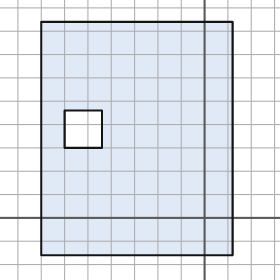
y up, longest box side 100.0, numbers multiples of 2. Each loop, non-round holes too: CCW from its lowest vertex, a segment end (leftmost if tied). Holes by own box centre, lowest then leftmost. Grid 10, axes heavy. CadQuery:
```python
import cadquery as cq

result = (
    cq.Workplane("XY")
    .moveTo(-70.0, -16.0)
    .lineTo(12.0, -16.0)
    .lineTo(12.0, 84.0)
    .lineTo(-70.0, 84.0)
    .close()
    .moveTo(-60.0, 30.0)
    .lineTo(-44.0, 30.0)
    .lineTo(-44.0, 46.0)
    .lineTo(-60.0, 46.0)
    .close()
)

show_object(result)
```